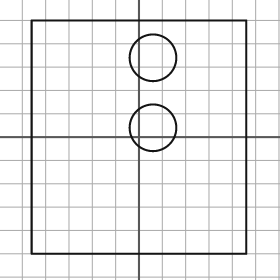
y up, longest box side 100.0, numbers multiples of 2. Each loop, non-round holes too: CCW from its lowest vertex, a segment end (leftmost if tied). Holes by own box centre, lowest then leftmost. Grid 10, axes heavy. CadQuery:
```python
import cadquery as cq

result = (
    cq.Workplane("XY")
    .moveTo(-46.0, -50.0)
    .lineTo(46.0, -50.0)
    .lineTo(46.0, 50.0)
    .lineTo(-46.0, 50.0)
    .close()
    .moveTo(6.0, 4.0)
    .circle(10.0)
    .moveTo(6.0, 34.0)
    .circle(10.0)
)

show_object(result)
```